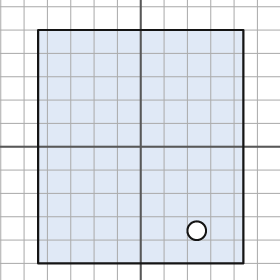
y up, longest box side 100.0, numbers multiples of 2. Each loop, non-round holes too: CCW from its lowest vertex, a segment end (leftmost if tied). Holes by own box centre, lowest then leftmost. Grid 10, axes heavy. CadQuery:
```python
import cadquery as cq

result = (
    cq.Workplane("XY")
    .moveTo(-44.0, -50.0)
    .lineTo(44.0, -50.0)
    .lineTo(44.0, 50.0)
    .lineTo(-44.0, 50.0)
    .close()
    .moveTo(24.0, -36.0)
    .circle(4.0)
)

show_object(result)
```